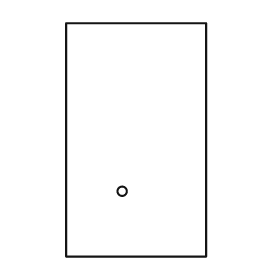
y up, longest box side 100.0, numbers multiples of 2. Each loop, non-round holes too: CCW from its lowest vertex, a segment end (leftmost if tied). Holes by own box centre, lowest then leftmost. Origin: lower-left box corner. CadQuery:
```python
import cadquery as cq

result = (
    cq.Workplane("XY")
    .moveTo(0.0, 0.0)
    .lineTo(60.0, 0.0)
    .lineTo(60.0, 100.0)
    .lineTo(0.0, 100.0)
    .close()
    .moveTo(24.0, 28.0)
    .circle(2.0)
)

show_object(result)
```